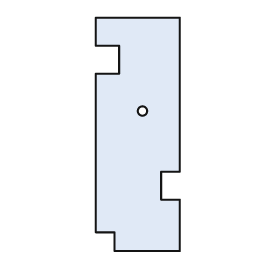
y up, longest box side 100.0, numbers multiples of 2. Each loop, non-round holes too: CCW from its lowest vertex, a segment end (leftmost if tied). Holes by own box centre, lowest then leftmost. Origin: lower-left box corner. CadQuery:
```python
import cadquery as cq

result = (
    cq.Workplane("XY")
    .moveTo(8.0, 0.0)
    .lineTo(36.0, 0.0)
    .lineTo(36.0, 22.0)
    .lineTo(28.0, 22.0)
    .lineTo(28.0, 34.0)
    .lineTo(36.0, 34.0)
    .lineTo(36.0, 100.0)
    .lineTo(0.0, 100.0)
    .lineTo(0.0, 88.0)
    .lineTo(10.0, 88.0)
    .lineTo(10.0, 76.0)
    .lineTo(0.0, 76.0)
    .lineTo(0.0, 8.0)
    .lineTo(8.0, 8.0)
    .close()
    .moveTo(20.0, 60.0)
    .circle(2.0)
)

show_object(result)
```